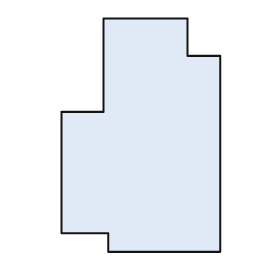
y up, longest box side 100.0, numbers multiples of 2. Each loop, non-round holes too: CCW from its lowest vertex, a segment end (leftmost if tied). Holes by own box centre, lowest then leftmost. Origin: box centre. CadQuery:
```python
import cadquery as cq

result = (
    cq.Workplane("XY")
    .moveTo(-14.0, -50.0)
    .lineTo(34.0, -50.0)
    .lineTo(34.0, 34.0)
    .lineTo(20.0, 34.0)
    .lineTo(20.0, 50.0)
    .lineTo(-16.0, 50.0)
    .lineTo(-16.0, 10.0)
    .lineTo(-34.0, 10.0)
    .lineTo(-34.0, -42.0)
    .lineTo(-14.0, -42.0)
    .close()
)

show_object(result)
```